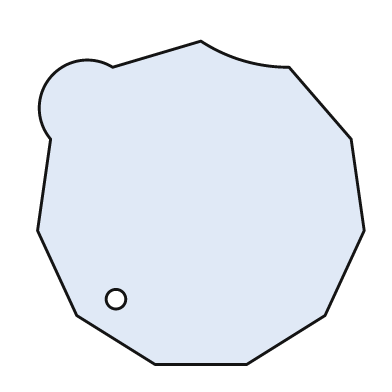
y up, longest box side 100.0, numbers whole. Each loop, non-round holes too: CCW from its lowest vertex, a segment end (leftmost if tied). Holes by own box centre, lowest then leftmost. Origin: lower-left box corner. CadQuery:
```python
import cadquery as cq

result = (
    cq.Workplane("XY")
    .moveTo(36.0, 0.0)
    .lineTo(64.0, 0.0)
    .lineTo(88.0, 15.0)
    .lineTo(100.0, 41.0)
    .lineTo(96.0, 69.0)
    .lineTo(77.0, 91.0)
    .threePointArc((63.0, 93.0), (50.0, 99.0))
    .lineTo(23.0, 91.0)
    .threePointArc((4.0, 88.0), (4.0, 69.0))
    .lineTo(0.0, 41.0)
    .lineTo(12.0, 15.0)
    .close()
    .moveTo(24.0, 20.0)
    .circle(3.0)
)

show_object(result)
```